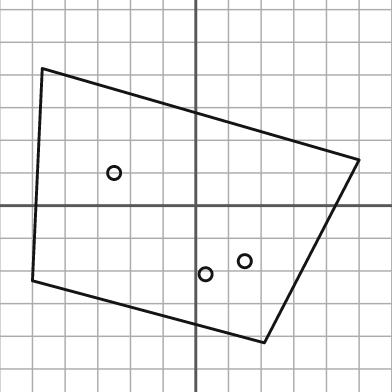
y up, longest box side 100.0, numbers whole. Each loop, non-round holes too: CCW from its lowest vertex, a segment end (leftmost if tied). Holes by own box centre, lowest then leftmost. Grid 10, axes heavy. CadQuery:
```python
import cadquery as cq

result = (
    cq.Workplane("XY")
    .moveTo(21.0, -42.0)
    .lineTo(50.0, 14.0)
    .lineTo(-47.0, 42.0)
    .lineTo(-50.0, -23.0)
    .close()
    .moveTo(3.0, -21.0)
    .circle(2.0)
    .moveTo(15.0, -17.0)
    .circle(2.0)
    .moveTo(-25.0, 10.0)
    .circle(2.0)
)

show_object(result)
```